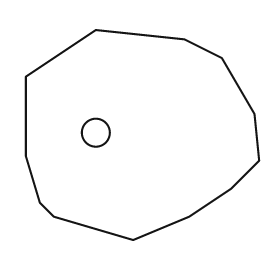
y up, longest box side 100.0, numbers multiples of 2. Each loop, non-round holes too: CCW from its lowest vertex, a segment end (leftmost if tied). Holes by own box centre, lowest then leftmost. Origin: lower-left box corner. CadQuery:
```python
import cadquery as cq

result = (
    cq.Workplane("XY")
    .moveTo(46.0, 0.0)
    .lineTo(70.0, 10.0)
    .lineTo(88.0, 22.0)
    .lineTo(100.0, 34.0)
    .lineTo(98.0, 54.0)
    .lineTo(84.0, 78.0)
    .lineTo(68.0, 86.0)
    .lineTo(30.0, 90.0)
    .lineTo(0.0, 70.0)
    .lineTo(0.0, 36.0)
    .lineTo(6.0, 16.0)
    .lineTo(12.0, 10.0)
    .close()
    .moveTo(30.0, 46.0)
    .circle(6.0)
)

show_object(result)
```